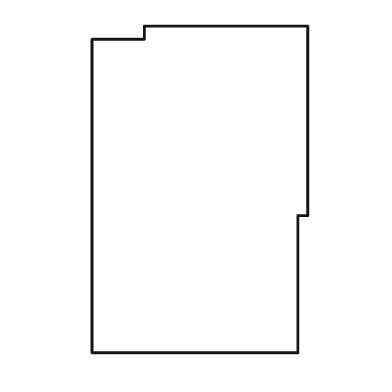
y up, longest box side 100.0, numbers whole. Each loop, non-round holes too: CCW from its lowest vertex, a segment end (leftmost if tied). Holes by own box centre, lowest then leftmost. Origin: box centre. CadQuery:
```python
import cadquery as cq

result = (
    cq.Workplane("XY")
    .moveTo(-33.0, -50.0)
    .lineTo(30.0, -50.0)
    .lineTo(30.0, -8.0)
    .lineTo(33.0, -8.0)
    .lineTo(33.0, 50.0)
    .lineTo(-17.0, 50.0)
    .lineTo(-17.0, 46.0)
    .lineTo(-33.0, 46.0)
    .close()
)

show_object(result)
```